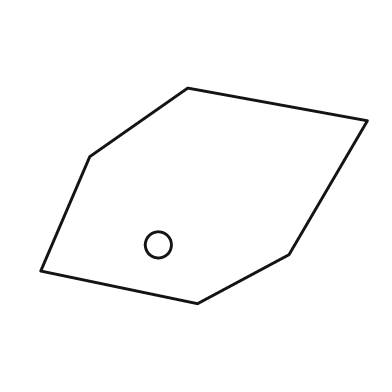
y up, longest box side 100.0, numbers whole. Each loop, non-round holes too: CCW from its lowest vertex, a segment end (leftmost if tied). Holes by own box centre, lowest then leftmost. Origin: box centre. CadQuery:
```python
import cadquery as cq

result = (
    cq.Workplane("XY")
    .moveTo(-2.0, -33.0)
    .lineTo(26.0, -18.0)
    .lineTo(50.0, 23.0)
    .lineTo(-5.0, 33.0)
    .lineTo(-35.0, 12.0)
    .lineTo(-50.0, -23.0)
    .close()
    .moveTo(-14.0, -15.0)
    .circle(4.0)
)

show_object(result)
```